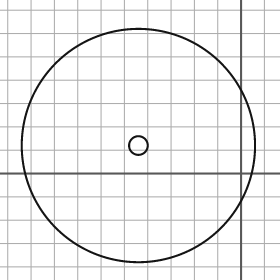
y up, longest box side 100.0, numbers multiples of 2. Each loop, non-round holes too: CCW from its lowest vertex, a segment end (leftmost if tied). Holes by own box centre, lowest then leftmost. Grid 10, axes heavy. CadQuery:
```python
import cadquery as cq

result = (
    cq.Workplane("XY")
    .moveTo(-44.0, 12.0)
    .circle(50.0)
    .moveTo(-44.0, 12.0)
    .circle(4.0)
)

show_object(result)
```